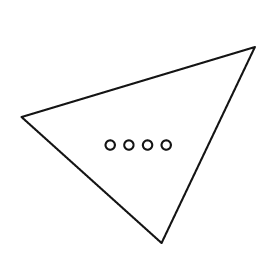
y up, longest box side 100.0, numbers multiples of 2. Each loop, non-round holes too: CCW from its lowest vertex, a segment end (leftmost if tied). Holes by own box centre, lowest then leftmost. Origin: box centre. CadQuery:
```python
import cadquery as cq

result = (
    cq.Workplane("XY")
    .moveTo(10.0, -42.0)
    .lineTo(50.0, 42.0)
    .lineTo(-50.0, 12.0)
    .close()
    .moveTo(-12.0, 0.0)
    .circle(2.0)
    .moveTo(-4.0, 0.0)
    .circle(2.0)
    .moveTo(4.0, 0.0)
    .circle(2.0)
    .moveTo(12.0, 0.0)
    .circle(2.0)
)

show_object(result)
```